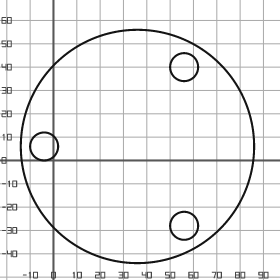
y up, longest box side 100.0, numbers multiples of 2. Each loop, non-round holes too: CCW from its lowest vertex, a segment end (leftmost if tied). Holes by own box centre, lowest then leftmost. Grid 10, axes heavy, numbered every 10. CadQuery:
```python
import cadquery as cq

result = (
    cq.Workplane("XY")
    .moveTo(36.0, 6.0)
    .circle(50.0)
    .moveTo(56.0, -28.0)
    .circle(6.0)
    .moveTo(-4.0, 6.0)
    .circle(6.0)
    .moveTo(56.0, 40.0)
    .circle(6.0)
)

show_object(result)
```